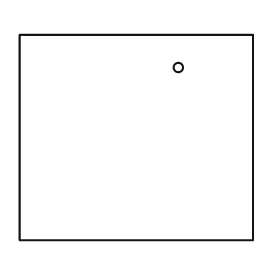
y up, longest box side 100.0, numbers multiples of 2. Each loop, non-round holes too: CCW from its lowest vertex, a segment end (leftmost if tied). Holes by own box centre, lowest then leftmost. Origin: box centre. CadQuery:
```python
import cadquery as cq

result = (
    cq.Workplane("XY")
    .moveTo(-50.0, -44.0)
    .lineTo(50.0, -44.0)
    .lineTo(50.0, 44.0)
    .lineTo(-50.0, 44.0)
    .close()
    .moveTo(18.0, 30.0)
    .circle(2.0)
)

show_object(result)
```